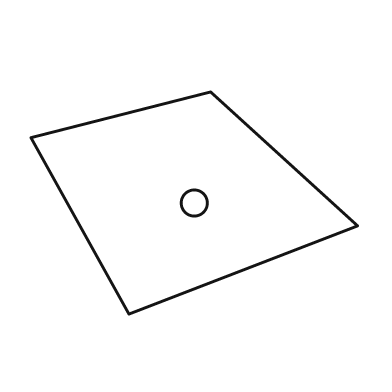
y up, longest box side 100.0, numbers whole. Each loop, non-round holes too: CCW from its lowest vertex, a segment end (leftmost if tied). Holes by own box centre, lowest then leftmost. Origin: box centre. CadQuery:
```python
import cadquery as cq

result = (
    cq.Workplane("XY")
    .moveTo(-20.0, -34.0)
    .lineTo(50.0, -7.0)
    .lineTo(5.0, 34.0)
    .lineTo(-50.0, 20.0)
    .close()
    .moveTo(0.0, 0.0)
    .circle(4.0)
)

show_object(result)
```